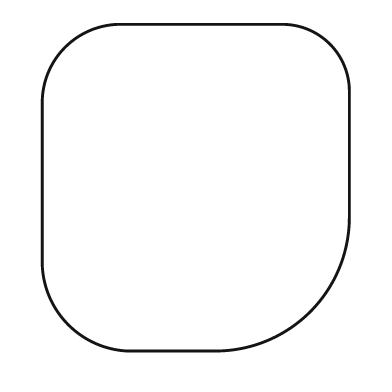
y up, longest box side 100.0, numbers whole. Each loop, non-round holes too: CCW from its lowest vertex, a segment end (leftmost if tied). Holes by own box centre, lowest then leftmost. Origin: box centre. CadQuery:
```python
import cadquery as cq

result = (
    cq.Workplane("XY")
    .moveTo(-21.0, -50.0)
    .lineTo(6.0, -50.0)
    .threePointArc((35.0, -38.0), (47.0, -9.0))
    .lineTo(47.0, 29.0)
    .threePointArc((41.0, 44.0), (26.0, 50.0))
    .lineTo(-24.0, 50.0)
    .threePointArc((-40.0, 43.0), (-47.0, 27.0))
    .lineTo(-47.0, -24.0)
    .threePointArc((-39.0, -42.0), (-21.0, -50.0))
    .close()
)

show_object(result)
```